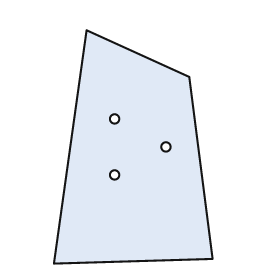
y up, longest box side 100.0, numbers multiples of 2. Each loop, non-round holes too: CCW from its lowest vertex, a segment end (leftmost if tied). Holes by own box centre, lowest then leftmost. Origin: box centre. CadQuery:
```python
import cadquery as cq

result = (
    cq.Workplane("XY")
    .moveTo(-34.0, -50.0)
    .lineTo(34.0, -48.0)
    .lineTo(24.0, 30.0)
    .lineTo(-20.0, 50.0)
    .close()
    .moveTo(-8.0, -12.0)
    .circle(2.0)
    .moveTo(14.0, 0.0)
    .circle(2.0)
    .moveTo(-8.0, 12.0)
    .circle(2.0)
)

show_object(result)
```